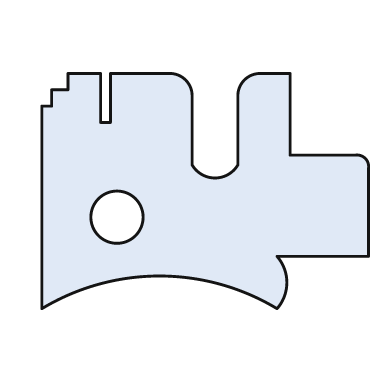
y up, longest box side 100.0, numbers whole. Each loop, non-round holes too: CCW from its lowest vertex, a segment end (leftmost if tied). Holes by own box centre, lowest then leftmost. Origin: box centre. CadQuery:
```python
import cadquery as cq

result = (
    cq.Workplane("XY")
    .moveTo(-50.0, -36.0)
    .threePointArc((-14.0, -26.0), (22.0, -36.0))
    .threePointArc((25.0, -28.0), (22.0, -20.0))
    .lineTo(50.0, -20.0)
    .lineTo(50.0, 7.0)
    .threePointArc((49.0, 10.0), (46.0, 11.0))
    .lineTo(26.0, 11.0)
    .lineTo(26.0, 36.0)
    .lineTo(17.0, 36.0)
    .threePointArc((12.0, 34.0), (10.0, 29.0))
    .lineTo(10.0, 8.0)
    .threePointArc((3.0, 4.0), (-4.0, 8.0))
    .lineTo(-4.0, 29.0)
    .threePointArc((-6.0, 34.0), (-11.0, 36.0))
    .lineTo(-29.0, 36.0)
    .lineTo(-29.0, 21.0)
    .lineTo(-32.0, 21.0)
    .lineTo(-32.0, 36.0)
    .lineTo(-42.0, 36.0)
    .lineTo(-42.0, 31.0)
    .lineTo(-47.0, 31.0)
    .lineTo(-47.0, 26.0)
    .lineTo(-50.0, 26.0)
    .close()
    .moveTo(-27.0, -8.0)
    .circle(8.0)
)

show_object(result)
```